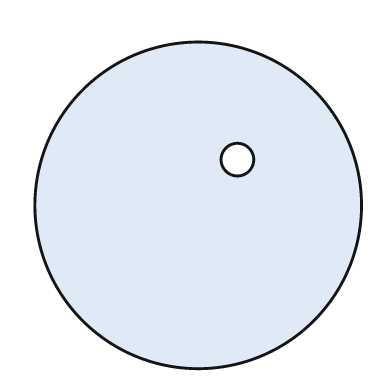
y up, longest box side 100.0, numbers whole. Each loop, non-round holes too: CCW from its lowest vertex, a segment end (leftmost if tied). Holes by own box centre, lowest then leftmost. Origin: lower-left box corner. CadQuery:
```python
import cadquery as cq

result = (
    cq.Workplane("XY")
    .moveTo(50.0, 50.0)
    .circle(50.0)
    .moveTo(62.0, 64.0)
    .circle(5.0)
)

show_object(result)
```